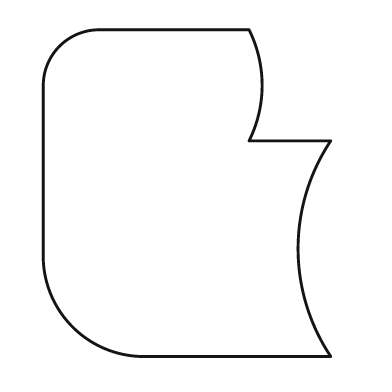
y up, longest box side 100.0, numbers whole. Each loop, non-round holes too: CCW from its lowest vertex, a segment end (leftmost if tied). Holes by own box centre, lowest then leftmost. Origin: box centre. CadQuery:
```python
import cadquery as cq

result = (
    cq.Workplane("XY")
    .moveTo(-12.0, -50.0)
    .lineTo(44.0, -50.0)
    .threePointArc((34.0, -17.0), (44.0, 16.0))
    .lineTo(19.0, 16.0)
    .threePointArc((23.0, 33.0), (19.0, 50.0))
    .lineTo(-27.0, 50.0)
    .threePointArc((-39.0, 45.0), (-44.0, 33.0))
    .lineTo(-44.0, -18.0)
    .threePointArc((-35.0, -41.0), (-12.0, -50.0))
    .close()
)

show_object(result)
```